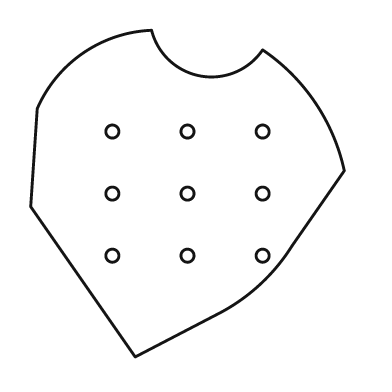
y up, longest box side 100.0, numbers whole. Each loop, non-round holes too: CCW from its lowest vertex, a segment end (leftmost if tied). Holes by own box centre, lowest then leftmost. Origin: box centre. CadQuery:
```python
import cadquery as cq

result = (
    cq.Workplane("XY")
    .moveTo(-16.0, -50.0)
    .lineTo(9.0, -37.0)
    .threePointArc((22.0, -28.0), (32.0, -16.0))
    .lineTo(48.0, 7.0)
    .threePointArc((39.0, 28.0), (23.0, 44.0))
    .threePointArc((4.0, 36.0), (-11.0, 50.0))
    .threePointArc((-32.0, 43.0), (-46.0, 26.0))
    .lineTo(-48.0, -4.0)
    .close()
    .moveTo(-23.0, -19.0)
    .circle(2.0)
    .moveTo(0.0, -19.0)
    .circle(2.0)
    .moveTo(23.0, -19.0)
    .circle(2.0)
    .moveTo(-23.0, 0.0)
    .circle(2.0)
    .moveTo(0.0, 0.0)
    .circle(2.0)
    .moveTo(23.0, 0.0)
    .circle(2.0)
    .moveTo(-23.0, 19.0)
    .circle(2.0)
    .moveTo(0.0, 19.0)
    .circle(2.0)
    .moveTo(23.0, 19.0)
    .circle(2.0)
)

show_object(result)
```